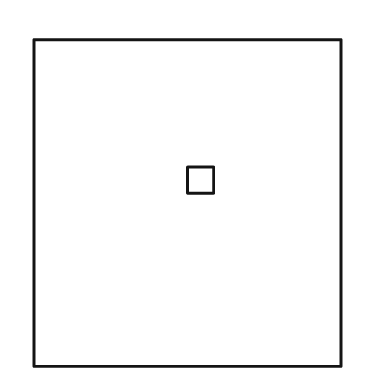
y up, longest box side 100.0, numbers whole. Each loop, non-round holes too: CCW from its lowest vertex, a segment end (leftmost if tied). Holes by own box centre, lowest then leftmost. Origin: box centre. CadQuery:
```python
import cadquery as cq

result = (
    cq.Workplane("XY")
    .moveTo(-47.0, -50.0)
    .lineTo(47.0, -50.0)
    .lineTo(47.0, 50.0)
    .lineTo(-47.0, 50.0)
    .close()
    .moveTo(0.0, 3.0)
    .lineTo(8.0, 3.0)
    .lineTo(8.0, 11.0)
    .lineTo(0.0, 11.0)
    .close()
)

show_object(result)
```